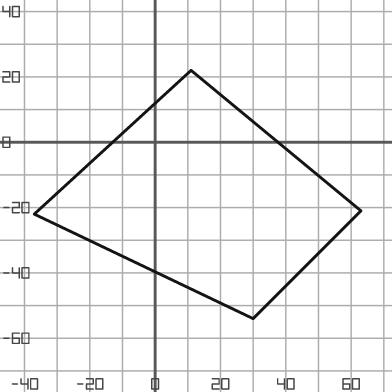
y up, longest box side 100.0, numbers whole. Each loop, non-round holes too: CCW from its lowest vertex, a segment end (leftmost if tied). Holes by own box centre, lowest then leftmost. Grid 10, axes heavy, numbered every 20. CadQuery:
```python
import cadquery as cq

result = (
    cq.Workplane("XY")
    .moveTo(30.0, -54.0)
    .lineTo(63.0, -21.0)
    .lineTo(11.0, 22.0)
    .lineTo(-37.0, -22.0)
    .close()
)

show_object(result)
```